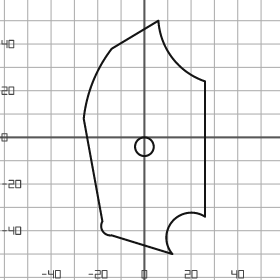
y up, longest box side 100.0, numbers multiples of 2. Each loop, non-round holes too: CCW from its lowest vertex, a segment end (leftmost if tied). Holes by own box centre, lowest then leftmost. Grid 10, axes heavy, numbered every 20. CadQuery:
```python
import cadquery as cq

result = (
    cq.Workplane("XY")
    .moveTo(12.0, -50.0)
    .threePointArc((12.0, -36.0), (26.0, -34.0))
    .lineTo(26.0, 24.0)
    .threePointArc((12.0, 34.0), (6.0, 50.0))
    .lineTo(-14.0, 38.0)
    .threePointArc((-22.0, 24.0), (-26.0, 8.0))
    .lineTo(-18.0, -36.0)
    .threePointArc((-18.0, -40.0), (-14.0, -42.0))
    .close()
    .moveTo(0.0, -4.0)
    .circle(4.0)
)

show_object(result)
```